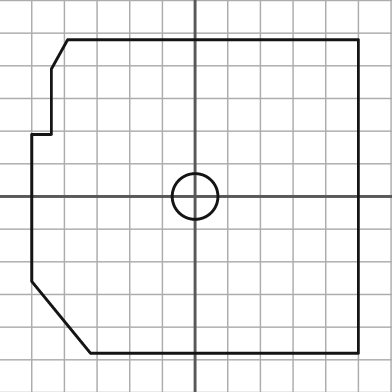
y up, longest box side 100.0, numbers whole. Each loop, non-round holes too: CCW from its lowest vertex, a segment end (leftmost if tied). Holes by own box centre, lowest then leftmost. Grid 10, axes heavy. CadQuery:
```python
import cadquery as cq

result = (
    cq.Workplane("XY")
    .moveTo(-32.0, -48.0)
    .lineTo(50.0, -48.0)
    .lineTo(50.0, 48.0)
    .lineTo(-39.0, 48.0)
    .lineTo(-44.0, 39.0)
    .lineTo(-44.0, 19.0)
    .lineTo(-50.0, 19.0)
    .lineTo(-50.0, -26.0)
    .close()
    .moveTo(0.0, 0.0)
    .circle(7.0)
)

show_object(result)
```